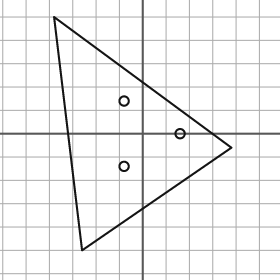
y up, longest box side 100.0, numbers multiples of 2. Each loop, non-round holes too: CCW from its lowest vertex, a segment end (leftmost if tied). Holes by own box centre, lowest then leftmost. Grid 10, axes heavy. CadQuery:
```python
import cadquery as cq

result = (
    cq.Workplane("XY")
    .moveTo(-26.0, -50.0)
    .lineTo(38.0, -6.0)
    .lineTo(-38.0, 50.0)
    .close()
    .moveTo(-8.0, -14.0)
    .circle(2.0)
    .moveTo(16.0, 0.0)
    .circle(2.0)
    .moveTo(-8.0, 14.0)
    .circle(2.0)
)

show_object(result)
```